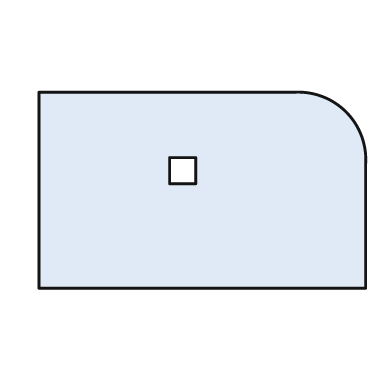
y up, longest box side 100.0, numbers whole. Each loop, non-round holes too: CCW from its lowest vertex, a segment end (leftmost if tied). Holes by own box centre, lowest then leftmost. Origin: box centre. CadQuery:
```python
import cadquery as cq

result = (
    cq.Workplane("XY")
    .moveTo(-50.0, -30.0)
    .lineTo(50.0, -30.0)
    .lineTo(50.0, 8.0)
    .threePointArc((44.0, 24.0), (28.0, 30.0))
    .lineTo(-50.0, 30.0)
    .close()
    .moveTo(-10.0, 2.0)
    .lineTo(-2.0, 2.0)
    .lineTo(-2.0, 10.0)
    .lineTo(-10.0, 10.0)
    .close()
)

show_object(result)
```